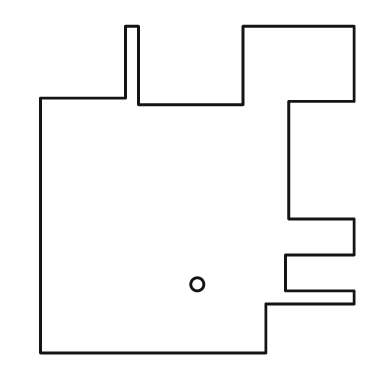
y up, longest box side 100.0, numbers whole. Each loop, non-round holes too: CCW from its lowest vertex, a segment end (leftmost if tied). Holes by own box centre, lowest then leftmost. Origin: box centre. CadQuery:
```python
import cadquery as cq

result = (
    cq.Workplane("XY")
    .moveTo(-48.0, -50.0)
    .lineTo(21.0, -50.0)
    .lineTo(21.0, -35.0)
    .lineTo(48.0, -35.0)
    .lineTo(48.0, -31.0)
    .lineTo(27.0, -31.0)
    .lineTo(27.0, -20.0)
    .lineTo(48.0, -20.0)
    .lineTo(48.0, -9.0)
    .lineTo(28.0, -9.0)
    .lineTo(28.0, 27.0)
    .lineTo(48.0, 27.0)
    .lineTo(48.0, 50.0)
    .lineTo(14.0, 50.0)
    .lineTo(14.0, 26.0)
    .lineTo(-18.0, 26.0)
    .lineTo(-18.0, 50.0)
    .lineTo(-22.0, 50.0)
    .lineTo(-22.0, 28.0)
    .lineTo(-48.0, 28.0)
    .close()
    .moveTo(0.0, -29.0)
    .circle(2.0)
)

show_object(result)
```